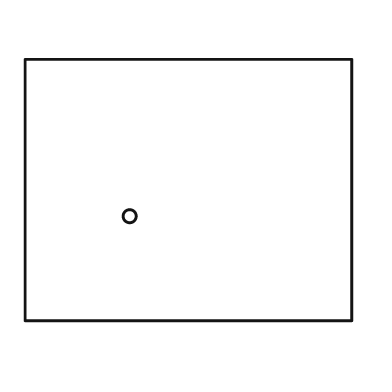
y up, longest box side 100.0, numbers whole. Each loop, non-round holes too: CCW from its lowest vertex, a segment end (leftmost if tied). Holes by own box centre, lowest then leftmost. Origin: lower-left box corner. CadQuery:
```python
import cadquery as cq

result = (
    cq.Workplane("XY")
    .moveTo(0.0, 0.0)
    .lineTo(100.0, 0.0)
    .lineTo(100.0, 80.0)
    .lineTo(0.0, 80.0)
    .close()
    .moveTo(32.0, 32.0)
    .circle(2.0)
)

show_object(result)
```